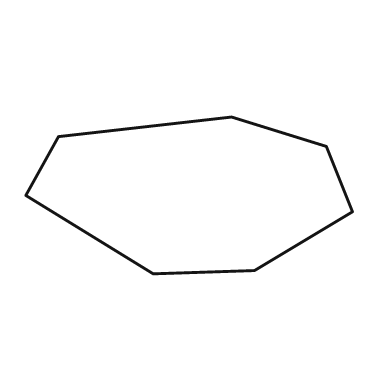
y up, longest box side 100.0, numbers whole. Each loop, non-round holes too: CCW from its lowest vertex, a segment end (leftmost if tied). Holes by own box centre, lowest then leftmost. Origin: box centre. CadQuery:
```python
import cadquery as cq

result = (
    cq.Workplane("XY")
    .moveTo(-11.0, -24.0)
    .lineTo(20.0, -23.0)
    .lineTo(50.0, -5.0)
    .lineTo(42.0, 15.0)
    .lineTo(13.0, 24.0)
    .lineTo(-40.0, 18.0)
    .lineTo(-50.0, 0.0)
    .close()
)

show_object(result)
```